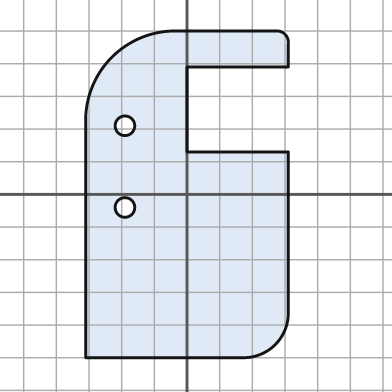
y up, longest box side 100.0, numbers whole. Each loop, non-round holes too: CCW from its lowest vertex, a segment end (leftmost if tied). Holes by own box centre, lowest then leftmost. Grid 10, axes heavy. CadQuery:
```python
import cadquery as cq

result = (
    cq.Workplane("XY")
    .moveTo(-31.0, -50.0)
    .lineTo(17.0, -50.0)
    .threePointArc((27.0, -46.0), (31.0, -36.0))
    .lineTo(31.0, 13.0)
    .lineTo(0.0, 13.0)
    .lineTo(0.0, 39.0)
    .lineTo(31.0, 39.0)
    .lineTo(31.0, 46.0)
    .threePointArc((30.0, 49.0), (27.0, 50.0))
    .lineTo(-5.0, 50.0)
    .threePointArc((-23.0, 42.0), (-31.0, 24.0))
    .close()
    .moveTo(-19.0, -4.0)
    .circle(3.0)
    .moveTo(-19.0, 21.0)
    .circle(3.0)
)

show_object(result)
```